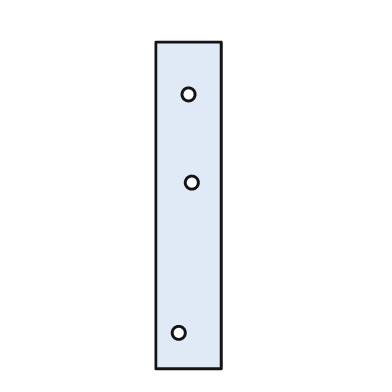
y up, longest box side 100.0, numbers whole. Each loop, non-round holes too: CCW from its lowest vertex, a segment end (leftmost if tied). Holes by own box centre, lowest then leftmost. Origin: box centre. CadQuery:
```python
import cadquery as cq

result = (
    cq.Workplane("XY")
    .moveTo(-10.0, -50.0)
    .lineTo(10.0, -50.0)
    .lineTo(10.0, 50.0)
    .lineTo(-10.0, 50.0)
    .close()
    .moveTo(-3.0, -39.0)
    .circle(2.0)
    .moveTo(1.0, 7.0)
    .circle(2.0)
    .moveTo(0.0, 34.0)
    .circle(2.0)
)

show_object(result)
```